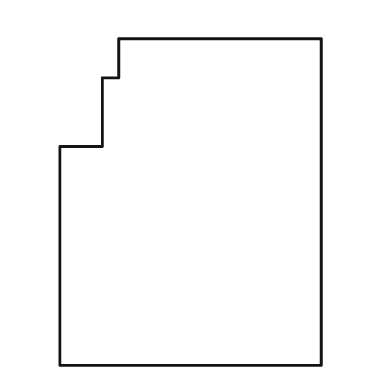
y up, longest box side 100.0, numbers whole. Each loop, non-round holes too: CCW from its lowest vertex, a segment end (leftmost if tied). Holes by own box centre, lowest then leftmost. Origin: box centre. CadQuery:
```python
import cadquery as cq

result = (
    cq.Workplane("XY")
    .moveTo(-40.0, -50.0)
    .lineTo(40.0, -50.0)
    .lineTo(40.0, 50.0)
    .lineTo(-22.0, 50.0)
    .lineTo(-22.0, 38.0)
    .lineTo(-27.0, 38.0)
    .lineTo(-27.0, 17.0)
    .lineTo(-40.0, 17.0)
    .close()
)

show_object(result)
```